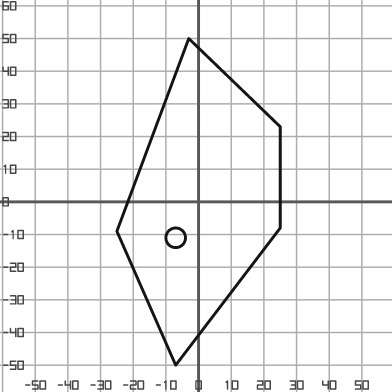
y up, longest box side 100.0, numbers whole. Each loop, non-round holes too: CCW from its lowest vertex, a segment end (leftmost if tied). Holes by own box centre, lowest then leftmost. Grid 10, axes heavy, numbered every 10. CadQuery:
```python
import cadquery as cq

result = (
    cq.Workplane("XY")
    .moveTo(-7.0, -50.0)
    .lineTo(25.0, -8.0)
    .lineTo(25.0, 23.0)
    .lineTo(-3.0, 50.0)
    .lineTo(-25.0, -9.0)
    .close()
    .moveTo(-7.0, -11.0)
    .circle(3.0)
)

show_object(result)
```